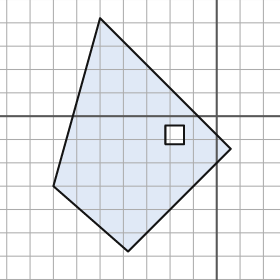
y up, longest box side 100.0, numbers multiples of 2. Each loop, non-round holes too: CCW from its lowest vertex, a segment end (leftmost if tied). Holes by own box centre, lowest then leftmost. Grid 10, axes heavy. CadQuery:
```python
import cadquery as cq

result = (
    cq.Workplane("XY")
    .moveTo(-38.0, -58.0)
    .lineTo(6.0, -14.0)
    .lineTo(-50.0, 42.0)
    .lineTo(-70.0, -30.0)
    .close()
    .moveTo(-22.0, -12.0)
    .lineTo(-14.0, -12.0)
    .lineTo(-14.0, -4.0)
    .lineTo(-22.0, -4.0)
    .close()
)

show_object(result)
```